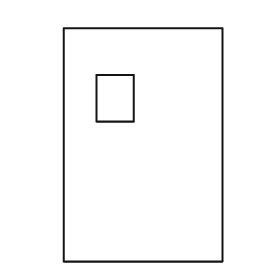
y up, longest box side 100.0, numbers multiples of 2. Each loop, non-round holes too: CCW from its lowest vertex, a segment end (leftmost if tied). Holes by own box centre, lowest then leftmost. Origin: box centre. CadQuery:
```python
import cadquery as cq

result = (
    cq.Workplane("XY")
    .moveTo(-34.0, -50.0)
    .lineTo(34.0, -50.0)
    .lineTo(34.0, 50.0)
    .lineTo(-34.0, 50.0)
    .close()
    .moveTo(-20.0, 10.0)
    .lineTo(-4.0, 10.0)
    .lineTo(-4.0, 30.0)
    .lineTo(-20.0, 30.0)
    .close()
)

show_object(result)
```